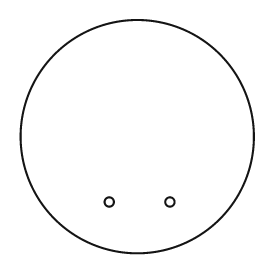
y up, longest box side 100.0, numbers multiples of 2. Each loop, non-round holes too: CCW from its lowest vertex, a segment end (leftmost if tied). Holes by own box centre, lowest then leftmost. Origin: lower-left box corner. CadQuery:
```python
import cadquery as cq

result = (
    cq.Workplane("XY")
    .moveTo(50.0, 50.0)
    .circle(50.0)
    .moveTo(38.0, 22.0)
    .circle(2.0)
    .moveTo(64.0, 22.0)
    .circle(2.0)
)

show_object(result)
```